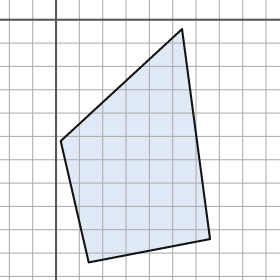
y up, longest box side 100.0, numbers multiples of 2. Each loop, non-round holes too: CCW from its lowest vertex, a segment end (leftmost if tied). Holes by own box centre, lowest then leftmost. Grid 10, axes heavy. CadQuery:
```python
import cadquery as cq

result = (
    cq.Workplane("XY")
    .moveTo(14.0, -104.0)
    .lineTo(66.0, -94.0)
    .lineTo(54.0, -4.0)
    .lineTo(2.0, -52.0)
    .close()
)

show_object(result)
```